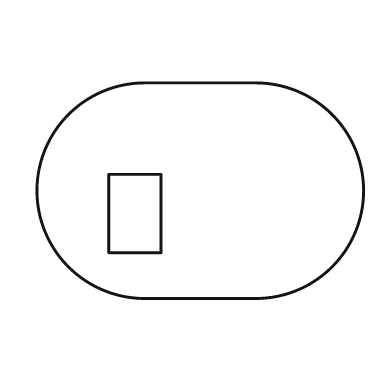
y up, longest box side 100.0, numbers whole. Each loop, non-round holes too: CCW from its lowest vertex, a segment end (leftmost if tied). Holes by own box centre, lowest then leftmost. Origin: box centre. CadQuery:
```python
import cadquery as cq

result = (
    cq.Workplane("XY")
    .moveTo(-17.0, -33.0)
    .lineTo(17.0, -33.0)
    .threePointArc((50.0, 0.0), (17.0, 33.0))
    .lineTo(-17.0, 33.0)
    .threePointArc((-50.0, 0.0), (-17.0, -33.0))
    .close()
    .moveTo(-28.0, -19.0)
    .lineTo(-12.0, -19.0)
    .lineTo(-12.0, 5.0)
    .lineTo(-28.0, 5.0)
    .close()
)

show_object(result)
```